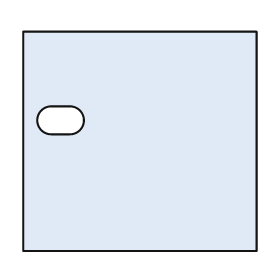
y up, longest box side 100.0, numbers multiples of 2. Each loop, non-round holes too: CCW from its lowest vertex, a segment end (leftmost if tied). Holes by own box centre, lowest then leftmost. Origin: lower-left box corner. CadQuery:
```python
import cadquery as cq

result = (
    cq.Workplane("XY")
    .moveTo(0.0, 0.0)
    .lineTo(100.0, 0.0)
    .lineTo(100.0, 94.0)
    .lineTo(0.0, 94.0)
    .close()
    .moveTo(12.0, 50.0)
    .lineTo(20.0, 50.0)
    .threePointArc((26.0, 56.0), (20.0, 62.0))
    .lineTo(12.0, 62.0)
    .threePointArc((6.0, 56.0), (12.0, 50.0))
    .close()
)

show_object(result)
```